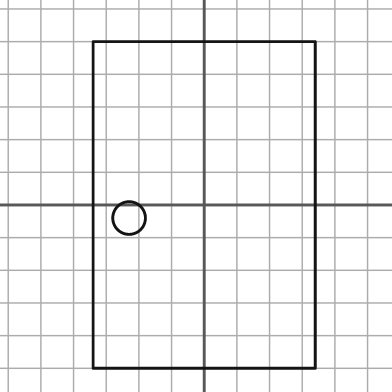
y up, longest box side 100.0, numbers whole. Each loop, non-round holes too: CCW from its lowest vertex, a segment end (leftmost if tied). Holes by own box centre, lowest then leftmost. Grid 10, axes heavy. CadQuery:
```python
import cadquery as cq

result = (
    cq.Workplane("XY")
    .moveTo(-34.0, -50.0)
    .lineTo(34.0, -50.0)
    .lineTo(34.0, 50.0)
    .lineTo(-34.0, 50.0)
    .close()
    .moveTo(-23.0, -4.0)
    .circle(5.0)
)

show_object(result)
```